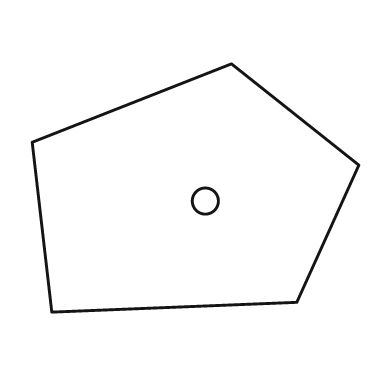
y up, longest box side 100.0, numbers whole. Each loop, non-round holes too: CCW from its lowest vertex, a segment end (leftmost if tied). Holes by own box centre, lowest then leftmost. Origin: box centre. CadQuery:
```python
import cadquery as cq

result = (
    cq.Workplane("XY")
    .moveTo(-44.0, -38.0)
    .lineTo(31.0, -35.0)
    .lineTo(50.0, 7.0)
    .lineTo(11.0, 38.0)
    .lineTo(-50.0, 14.0)
    .close()
    .moveTo(3.0, -4.0)
    .circle(4.0)
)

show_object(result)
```